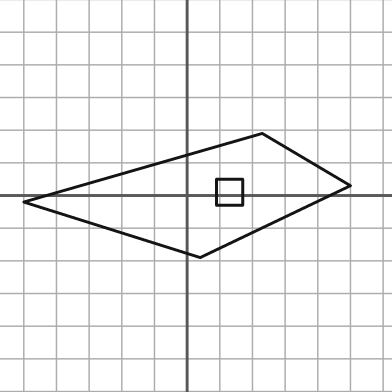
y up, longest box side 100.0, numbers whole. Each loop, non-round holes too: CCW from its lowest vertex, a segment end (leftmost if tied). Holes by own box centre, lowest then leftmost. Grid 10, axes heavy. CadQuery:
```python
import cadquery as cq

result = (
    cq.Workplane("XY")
    .moveTo(4.0, -19.0)
    .lineTo(50.0, 3.0)
    .lineTo(23.0, 19.0)
    .lineTo(-50.0, -2.0)
    .close()
    .moveTo(9.0, -3.0)
    .lineTo(17.0, -3.0)
    .lineTo(17.0, 5.0)
    .lineTo(9.0, 5.0)
    .close()
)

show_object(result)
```